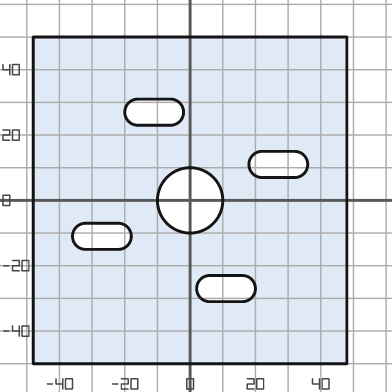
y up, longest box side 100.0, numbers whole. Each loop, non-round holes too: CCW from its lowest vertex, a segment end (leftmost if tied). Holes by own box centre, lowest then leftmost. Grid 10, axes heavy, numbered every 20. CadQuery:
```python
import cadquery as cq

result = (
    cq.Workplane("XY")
    .moveTo(-48.0, -50.0)
    .lineTo(48.0, -50.0)
    .lineTo(48.0, 50.0)
    .lineTo(-48.0, 50.0)
    .close()
    .moveTo(6.0, -31.0)
    .lineTo(16.0, -31.0)
    .threePointArc((20.0, -27.0), (16.0, -23.0))
    .lineTo(6.0, -23.0)
    .threePointArc((2.0, -27.0), (6.0, -31.0))
    .close()
    .moveTo(-32.0, -15.0)
    .lineTo(-22.0, -15.0)
    .threePointArc((-18.0, -11.0), (-22.0, -7.0))
    .lineTo(-32.0, -7.0)
    .threePointArc((-36.0, -11.0), (-32.0, -15.0))
    .close()
    .moveTo(0.0, 0.0)
    .circle(10.0)
    .moveTo(22.0, 7.0)
    .lineTo(32.0, 7.0)
    .threePointArc((36.0, 11.0), (32.0, 15.0))
    .lineTo(22.0, 15.0)
    .threePointArc((18.0, 11.0), (22.0, 7.0))
    .close()
    .moveTo(-16.0, 23.0)
    .lineTo(-6.0, 23.0)
    .threePointArc((-2.0, 27.0), (-6.0, 31.0))
    .lineTo(-16.0, 31.0)
    .threePointArc((-20.0, 27.0), (-16.0, 23.0))
    .close()
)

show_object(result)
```